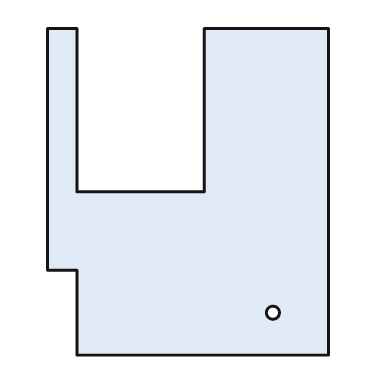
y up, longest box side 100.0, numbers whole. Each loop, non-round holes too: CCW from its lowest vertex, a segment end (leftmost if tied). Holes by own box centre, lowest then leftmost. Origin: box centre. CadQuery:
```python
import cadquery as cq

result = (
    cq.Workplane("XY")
    .moveTo(-34.0, -50.0)
    .lineTo(43.0, -50.0)
    .lineTo(43.0, 50.0)
    .lineTo(5.0, 50.0)
    .lineTo(5.0, 0.0)
    .lineTo(-34.0, 0.0)
    .lineTo(-34.0, 50.0)
    .lineTo(-43.0, 50.0)
    .lineTo(-43.0, -24.0)
    .lineTo(-34.0, -24.0)
    .close()
    .moveTo(26.0, -37.0)
    .circle(2.0)
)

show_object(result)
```